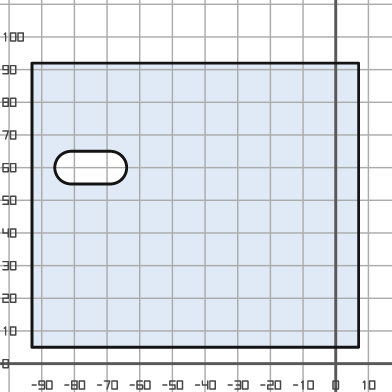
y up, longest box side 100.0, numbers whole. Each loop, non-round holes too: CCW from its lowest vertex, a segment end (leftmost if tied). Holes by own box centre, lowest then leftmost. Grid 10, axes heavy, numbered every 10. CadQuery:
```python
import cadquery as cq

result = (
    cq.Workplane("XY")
    .moveTo(-93.0, 5.0)
    .lineTo(7.0, 5.0)
    .lineTo(7.0, 92.0)
    .lineTo(-93.0, 92.0)
    .close()
    .moveTo(-81.0, 55.0)
    .lineTo(-69.0, 55.0)
    .threePointArc((-64.0, 60.0), (-69.0, 65.0))
    .lineTo(-81.0, 65.0)
    .threePointArc((-86.0, 60.0), (-81.0, 55.0))
    .close()
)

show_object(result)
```